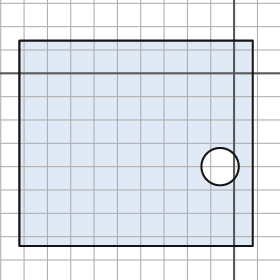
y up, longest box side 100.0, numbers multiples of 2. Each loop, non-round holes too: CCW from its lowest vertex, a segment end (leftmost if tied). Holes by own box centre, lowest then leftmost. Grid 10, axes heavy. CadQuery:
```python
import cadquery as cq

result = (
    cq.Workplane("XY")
    .moveTo(-92.0, -74.0)
    .lineTo(8.0, -74.0)
    .lineTo(8.0, 14.0)
    .lineTo(-92.0, 14.0)
    .close()
    .moveTo(-6.0, -40.0)
    .circle(8.0)
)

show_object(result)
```